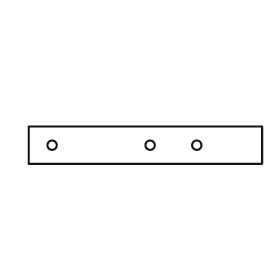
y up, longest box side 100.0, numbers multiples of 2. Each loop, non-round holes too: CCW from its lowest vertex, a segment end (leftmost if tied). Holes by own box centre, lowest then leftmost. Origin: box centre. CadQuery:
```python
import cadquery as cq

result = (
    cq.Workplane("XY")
    .moveTo(-50.0, -8.0)
    .lineTo(50.0, -8.0)
    .lineTo(50.0, 8.0)
    .lineTo(-50.0, 8.0)
    .close()
    .moveTo(-40.0, 0.0)
    .circle(2.0)
    .moveTo(2.0, 0.0)
    .circle(2.0)
    .moveTo(22.0, 0.0)
    .circle(2.0)
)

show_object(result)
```